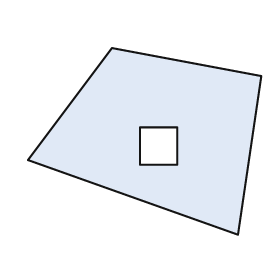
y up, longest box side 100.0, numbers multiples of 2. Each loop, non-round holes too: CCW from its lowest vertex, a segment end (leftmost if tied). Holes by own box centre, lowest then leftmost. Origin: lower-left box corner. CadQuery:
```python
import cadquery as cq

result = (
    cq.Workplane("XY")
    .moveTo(90.0, 0.0)
    .lineTo(100.0, 68.0)
    .lineTo(36.0, 80.0)
    .lineTo(0.0, 32.0)
    .close()
    .moveTo(48.0, 30.0)
    .lineTo(64.0, 30.0)
    .lineTo(64.0, 46.0)
    .lineTo(48.0, 46.0)
    .close()
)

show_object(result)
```